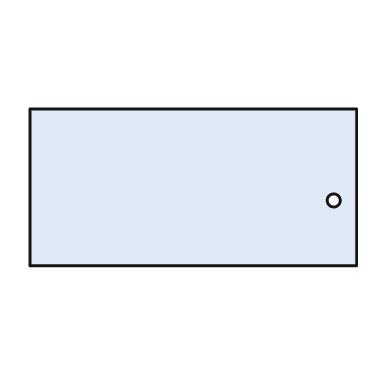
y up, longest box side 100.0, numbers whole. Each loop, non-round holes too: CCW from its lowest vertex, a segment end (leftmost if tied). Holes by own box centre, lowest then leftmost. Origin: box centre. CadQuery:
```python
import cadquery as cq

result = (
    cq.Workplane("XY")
    .moveTo(-50.0, -24.0)
    .lineTo(50.0, -24.0)
    .lineTo(50.0, 24.0)
    .lineTo(-50.0, 24.0)
    .close()
    .moveTo(43.0, -4.0)
    .circle(2.0)
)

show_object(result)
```